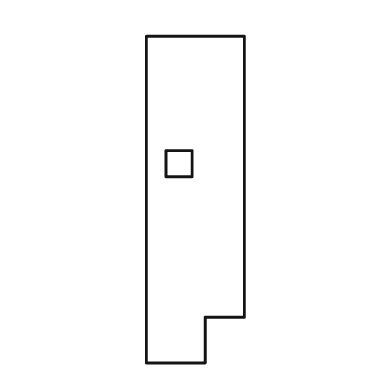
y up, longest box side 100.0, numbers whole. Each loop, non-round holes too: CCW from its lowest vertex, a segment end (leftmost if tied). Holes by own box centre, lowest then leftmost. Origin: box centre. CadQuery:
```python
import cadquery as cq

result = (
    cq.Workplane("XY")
    .moveTo(-15.0, -50.0)
    .lineTo(3.0, -50.0)
    .lineTo(3.0, -36.0)
    .lineTo(15.0, -36.0)
    .lineTo(15.0, 50.0)
    .lineTo(-15.0, 50.0)
    .close()
    .moveTo(-9.0, 7.0)
    .lineTo(-1.0, 7.0)
    .lineTo(-1.0, 15.0)
    .lineTo(-9.0, 15.0)
    .close()
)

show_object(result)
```